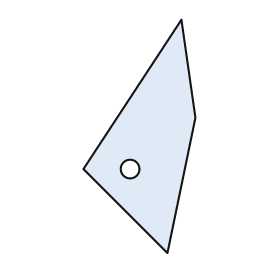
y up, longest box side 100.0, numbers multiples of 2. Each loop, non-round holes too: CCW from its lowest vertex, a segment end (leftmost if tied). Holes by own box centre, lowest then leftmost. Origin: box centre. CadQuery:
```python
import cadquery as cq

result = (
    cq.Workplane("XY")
    .moveTo(12.0, -50.0)
    .lineTo(24.0, 8.0)
    .lineTo(18.0, 50.0)
    .lineTo(-24.0, -14.0)
    .close()
    .moveTo(-4.0, -14.0)
    .circle(4.0)
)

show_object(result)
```